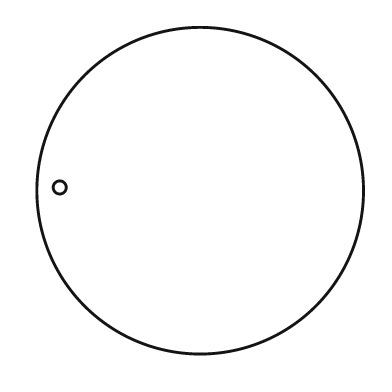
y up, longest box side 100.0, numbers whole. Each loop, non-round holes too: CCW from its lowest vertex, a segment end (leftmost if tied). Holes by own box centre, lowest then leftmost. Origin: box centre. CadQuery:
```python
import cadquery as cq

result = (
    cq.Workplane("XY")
    .moveTo(0.0, 0.0)
    .circle(50.0)
    .moveTo(-43.0, 1.0)
    .circle(2.0)
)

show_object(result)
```